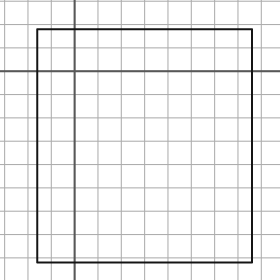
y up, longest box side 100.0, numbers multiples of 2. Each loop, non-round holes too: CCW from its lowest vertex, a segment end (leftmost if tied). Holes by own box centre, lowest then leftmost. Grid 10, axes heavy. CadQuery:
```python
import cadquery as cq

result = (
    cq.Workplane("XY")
    .moveTo(-16.0, -82.0)
    .lineTo(76.0, -82.0)
    .lineTo(76.0, 18.0)
    .lineTo(-16.0, 18.0)
    .close()
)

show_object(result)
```